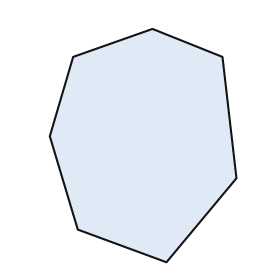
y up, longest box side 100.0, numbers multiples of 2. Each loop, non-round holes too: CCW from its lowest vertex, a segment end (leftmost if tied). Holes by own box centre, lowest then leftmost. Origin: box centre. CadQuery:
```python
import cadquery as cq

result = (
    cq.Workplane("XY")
    .moveTo(10.0, -50.0)
    .lineTo(40.0, -14.0)
    .lineTo(34.0, 38.0)
    .lineTo(4.0, 50.0)
    .lineTo(-30.0, 38.0)
    .lineTo(-40.0, 4.0)
    .lineTo(-28.0, -36.0)
    .close()
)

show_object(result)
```